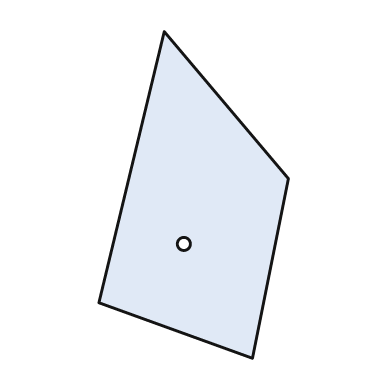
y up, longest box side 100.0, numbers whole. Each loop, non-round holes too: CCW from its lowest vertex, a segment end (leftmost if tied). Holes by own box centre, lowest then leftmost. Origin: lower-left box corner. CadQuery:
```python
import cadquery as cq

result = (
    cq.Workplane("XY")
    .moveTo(47.0, 0.0)
    .lineTo(58.0, 55.0)
    .lineTo(20.0, 100.0)
    .lineTo(0.0, 17.0)
    .close()
    .moveTo(26.0, 35.0)
    .circle(2.0)
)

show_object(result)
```